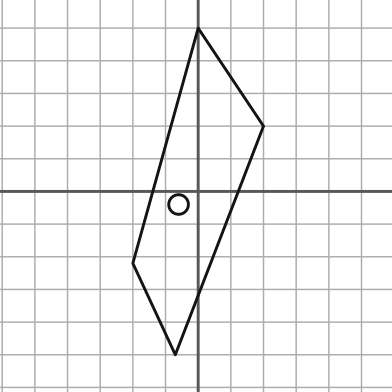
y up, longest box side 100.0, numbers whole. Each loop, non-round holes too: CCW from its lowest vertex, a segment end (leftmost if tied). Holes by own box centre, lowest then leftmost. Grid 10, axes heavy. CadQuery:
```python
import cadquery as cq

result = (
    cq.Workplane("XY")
    .moveTo(-7.0, -50.0)
    .lineTo(20.0, 20.0)
    .lineTo(0.0, 50.0)
    .lineTo(-20.0, -22.0)
    .close()
    .moveTo(-6.0, -4.0)
    .circle(3.0)
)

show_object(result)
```